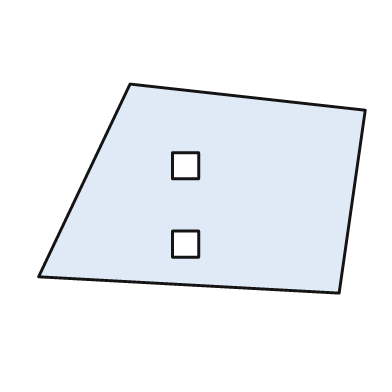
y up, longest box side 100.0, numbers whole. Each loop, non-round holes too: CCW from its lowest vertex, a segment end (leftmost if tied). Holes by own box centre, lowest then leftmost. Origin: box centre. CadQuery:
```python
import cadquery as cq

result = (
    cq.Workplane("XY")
    .moveTo(42.0, -32.0)
    .lineTo(50.0, 24.0)
    .lineTo(-22.0, 32.0)
    .lineTo(-50.0, -27.0)
    .close()
    .moveTo(-9.0, -21.0)
    .lineTo(-1.0, -21.0)
    .lineTo(-1.0, -13.0)
    .lineTo(-9.0, -13.0)
    .close()
    .moveTo(-9.0, 3.0)
    .lineTo(-1.0, 3.0)
    .lineTo(-1.0, 11.0)
    .lineTo(-9.0, 11.0)
    .close()
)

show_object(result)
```